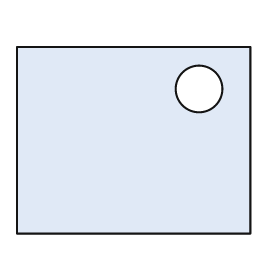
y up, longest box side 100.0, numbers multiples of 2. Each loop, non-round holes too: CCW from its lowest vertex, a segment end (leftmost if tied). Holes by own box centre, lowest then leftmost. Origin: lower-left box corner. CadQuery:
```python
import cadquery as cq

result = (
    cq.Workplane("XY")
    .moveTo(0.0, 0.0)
    .lineTo(100.0, 0.0)
    .lineTo(100.0, 80.0)
    .lineTo(0.0, 80.0)
    .close()
    .moveTo(78.0, 62.0)
    .circle(10.0)
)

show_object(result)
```